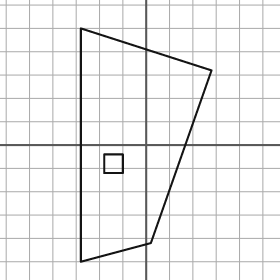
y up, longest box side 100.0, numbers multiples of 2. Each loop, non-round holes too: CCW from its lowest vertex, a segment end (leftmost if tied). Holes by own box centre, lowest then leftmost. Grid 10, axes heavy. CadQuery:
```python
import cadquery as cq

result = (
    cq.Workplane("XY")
    .moveTo(-28.0, -50.0)
    .lineTo(2.0, -42.0)
    .lineTo(28.0, 32.0)
    .lineTo(-28.0, 50.0)
    .close()
    .moveTo(-18.0, -12.0)
    .lineTo(-10.0, -12.0)
    .lineTo(-10.0, -4.0)
    .lineTo(-18.0, -4.0)
    .close()
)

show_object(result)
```